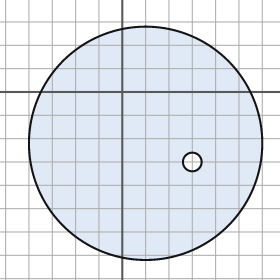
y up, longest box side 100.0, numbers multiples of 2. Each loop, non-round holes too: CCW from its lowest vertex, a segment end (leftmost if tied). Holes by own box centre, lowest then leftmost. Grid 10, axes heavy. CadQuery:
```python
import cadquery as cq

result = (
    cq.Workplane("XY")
    .moveTo(10.0, -22.0)
    .circle(50.0)
    .moveTo(30.0, -30.0)
    .circle(4.0)
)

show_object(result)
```